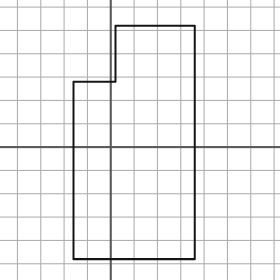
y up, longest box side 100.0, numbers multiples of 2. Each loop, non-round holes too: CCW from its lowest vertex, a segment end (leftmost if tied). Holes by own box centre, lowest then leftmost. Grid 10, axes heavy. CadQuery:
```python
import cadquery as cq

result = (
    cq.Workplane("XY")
    .moveTo(-16.0, -48.0)
    .lineTo(36.0, -48.0)
    .lineTo(36.0, 52.0)
    .lineTo(2.0, 52.0)
    .lineTo(2.0, 28.0)
    .lineTo(-16.0, 28.0)
    .close()
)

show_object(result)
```